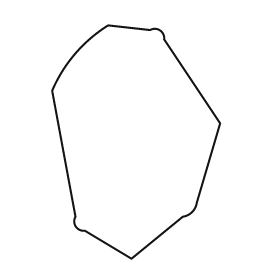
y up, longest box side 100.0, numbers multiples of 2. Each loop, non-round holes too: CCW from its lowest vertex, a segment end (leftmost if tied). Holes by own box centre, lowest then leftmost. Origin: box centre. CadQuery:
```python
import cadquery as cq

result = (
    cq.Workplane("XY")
    .moveTo(-2.0, -50.0)
    .lineTo(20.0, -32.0)
    .threePointArc((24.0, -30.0), (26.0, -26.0))
    .lineTo(36.0, 8.0)
    .lineTo(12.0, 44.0)
    .threePointArc((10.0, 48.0), (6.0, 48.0))
    .lineTo(-12.0, 50.0)
    .threePointArc((-26.0, 38.0), (-36.0, 22.0))
    .lineTo(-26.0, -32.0)
    .threePointArc((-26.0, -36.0), (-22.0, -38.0))
    .close()
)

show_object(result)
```